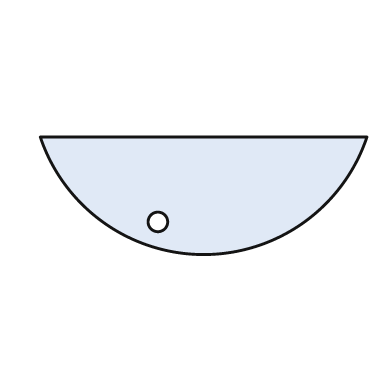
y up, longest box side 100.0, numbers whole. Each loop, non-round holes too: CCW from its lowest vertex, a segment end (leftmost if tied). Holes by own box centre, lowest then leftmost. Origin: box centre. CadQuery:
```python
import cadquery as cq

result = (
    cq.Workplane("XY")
    .moveTo(-50.0, 18.0)
    .threePointArc((0.0, -18.0), (50.0, 18.0))
    .close()
    .moveTo(-14.0, -8.0)
    .circle(3.0)
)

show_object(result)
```